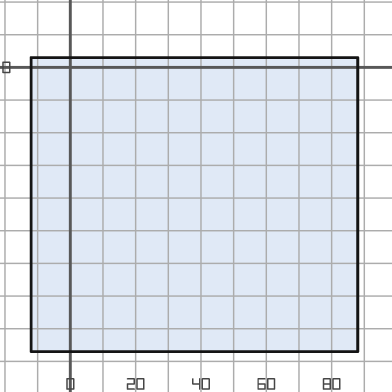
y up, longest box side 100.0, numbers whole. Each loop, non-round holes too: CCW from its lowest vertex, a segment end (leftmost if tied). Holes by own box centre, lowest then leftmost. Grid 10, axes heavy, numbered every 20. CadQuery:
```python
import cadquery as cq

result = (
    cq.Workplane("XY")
    .moveTo(-12.0, -87.0)
    .lineTo(88.0, -87.0)
    .lineTo(88.0, 3.0)
    .lineTo(-12.0, 3.0)
    .close()
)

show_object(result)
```